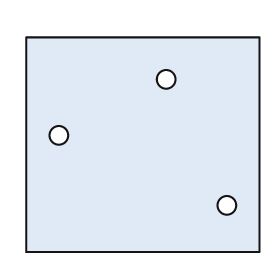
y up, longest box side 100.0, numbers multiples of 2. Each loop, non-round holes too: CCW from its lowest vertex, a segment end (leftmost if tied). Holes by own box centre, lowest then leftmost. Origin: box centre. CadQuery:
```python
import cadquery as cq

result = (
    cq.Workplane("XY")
    .moveTo(-50.0, -46.0)
    .lineTo(50.0, -46.0)
    .lineTo(50.0, 46.0)
    .lineTo(-50.0, 46.0)
    .close()
    .moveTo(36.0, -26.0)
    .circle(4.0)
    .moveTo(-36.0, 4.0)
    .circle(4.0)
    .moveTo(10.0, 28.0)
    .circle(4.0)
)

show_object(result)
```